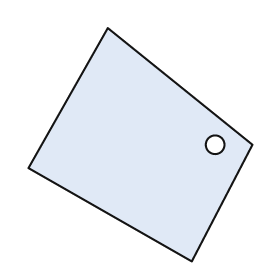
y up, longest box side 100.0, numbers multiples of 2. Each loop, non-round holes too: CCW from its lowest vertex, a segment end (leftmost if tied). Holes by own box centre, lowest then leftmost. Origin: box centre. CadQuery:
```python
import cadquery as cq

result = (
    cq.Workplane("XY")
    .moveTo(22.0, -50.0)
    .lineTo(48.0, 0.0)
    .lineTo(-14.0, 50.0)
    .lineTo(-48.0, -10.0)
    .close()
    .moveTo(32.0, 0.0)
    .circle(4.0)
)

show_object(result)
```